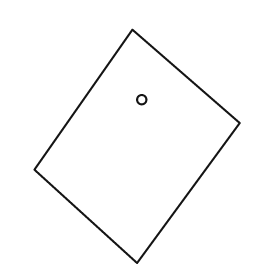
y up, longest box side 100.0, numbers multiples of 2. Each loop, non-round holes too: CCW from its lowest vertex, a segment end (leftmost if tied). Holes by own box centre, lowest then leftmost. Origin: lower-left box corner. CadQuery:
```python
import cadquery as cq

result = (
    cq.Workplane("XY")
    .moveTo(44.0, 0.0)
    .lineTo(88.0, 60.0)
    .lineTo(42.0, 100.0)
    .lineTo(0.0, 40.0)
    .close()
    .moveTo(46.0, 70.0)
    .circle(2.0)
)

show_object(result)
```